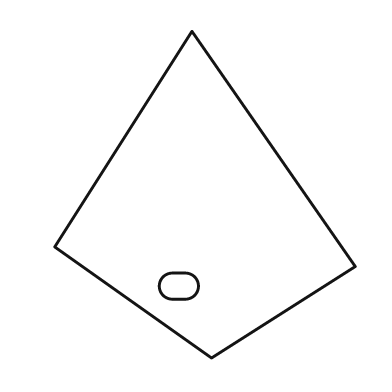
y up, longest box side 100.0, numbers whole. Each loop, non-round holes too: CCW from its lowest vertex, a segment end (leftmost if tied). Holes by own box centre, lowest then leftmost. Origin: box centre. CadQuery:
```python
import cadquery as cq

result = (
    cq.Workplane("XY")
    .moveTo(2.0, -50.0)
    .lineTo(46.0, -22.0)
    .lineTo(-4.0, 50.0)
    .lineTo(-46.0, -16.0)
    .close()
    .moveTo(-10.0, -32.0)
    .lineTo(-6.0, -32.0)
    .threePointArc((-2.0, -28.0), (-6.0, -24.0))
    .lineTo(-10.0, -24.0)
    .threePointArc((-14.0, -28.0), (-10.0, -32.0))
    .close()
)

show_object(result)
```